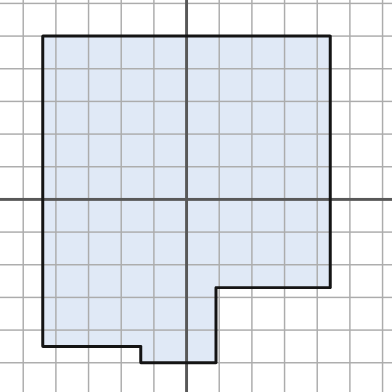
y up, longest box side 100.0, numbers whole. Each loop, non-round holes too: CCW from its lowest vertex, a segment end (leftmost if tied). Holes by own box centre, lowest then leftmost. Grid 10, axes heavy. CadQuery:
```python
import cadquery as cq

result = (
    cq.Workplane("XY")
    .moveTo(-14.0, -50.0)
    .lineTo(9.0, -50.0)
    .lineTo(9.0, -27.0)
    .lineTo(44.0, -27.0)
    .lineTo(44.0, 50.0)
    .lineTo(-44.0, 50.0)
    .lineTo(-44.0, -45.0)
    .lineTo(-14.0, -45.0)
    .close()
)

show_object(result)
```